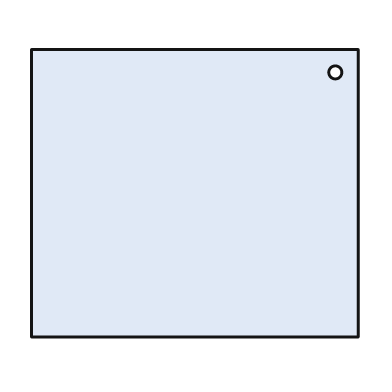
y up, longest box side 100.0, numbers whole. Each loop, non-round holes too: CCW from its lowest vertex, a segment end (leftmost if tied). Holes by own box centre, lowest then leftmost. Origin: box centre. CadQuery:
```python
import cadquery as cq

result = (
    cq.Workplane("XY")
    .moveTo(-50.0, -44.0)
    .lineTo(50.0, -44.0)
    .lineTo(50.0, 44.0)
    .lineTo(-50.0, 44.0)
    .close()
    .moveTo(43.0, 37.0)
    .circle(2.0)
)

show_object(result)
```